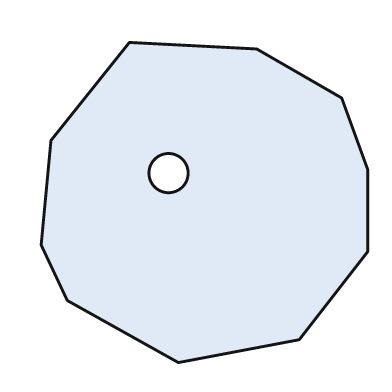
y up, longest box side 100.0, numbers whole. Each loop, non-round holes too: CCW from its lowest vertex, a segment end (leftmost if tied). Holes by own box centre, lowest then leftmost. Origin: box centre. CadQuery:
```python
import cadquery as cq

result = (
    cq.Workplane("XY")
    .moveTo(-8.0, -49.0)
    .lineTo(29.0, -42.0)
    .lineTo(50.0, -15.0)
    .lineTo(50.0, 10.0)
    .lineTo(42.0, 32.0)
    .lineTo(16.0, 47.0)
    .lineTo(-23.0, 49.0)
    .lineTo(-47.0, 19.0)
    .lineTo(-50.0, -13.0)
    .lineTo(-42.0, -30.0)
    .close()
    .moveTo(-11.0, 9.0)
    .circle(6.0)
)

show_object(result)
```